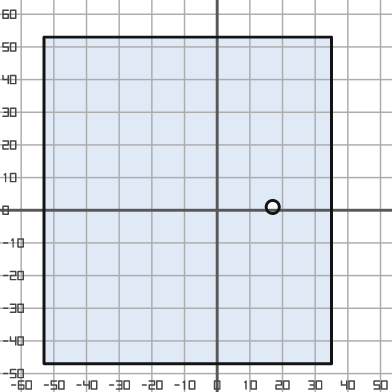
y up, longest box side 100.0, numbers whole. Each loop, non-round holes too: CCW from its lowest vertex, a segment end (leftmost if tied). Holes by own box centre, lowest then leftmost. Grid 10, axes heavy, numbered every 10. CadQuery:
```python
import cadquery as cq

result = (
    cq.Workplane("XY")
    .moveTo(-53.0, -47.0)
    .lineTo(35.0, -47.0)
    .lineTo(35.0, 53.0)
    .lineTo(-53.0, 53.0)
    .close()
    .moveTo(17.0, 1.0)
    .circle(2.0)
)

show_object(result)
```